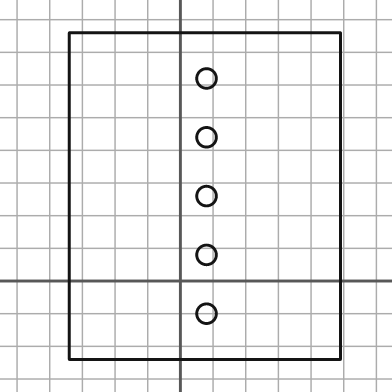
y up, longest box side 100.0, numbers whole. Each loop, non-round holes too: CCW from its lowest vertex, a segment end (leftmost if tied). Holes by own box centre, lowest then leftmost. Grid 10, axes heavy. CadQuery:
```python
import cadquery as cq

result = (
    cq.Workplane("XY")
    .moveTo(-34.0, -24.0)
    .lineTo(49.0, -24.0)
    .lineTo(49.0, 76.0)
    .lineTo(-34.0, 76.0)
    .close()
    .moveTo(8.0, -10.0)
    .circle(3.0)
    .moveTo(8.0, 8.0)
    .circle(3.0)
    .moveTo(8.0, 26.0)
    .circle(3.0)
    .moveTo(8.0, 44.0)
    .circle(3.0)
    .moveTo(8.0, 62.0)
    .circle(3.0)
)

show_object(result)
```